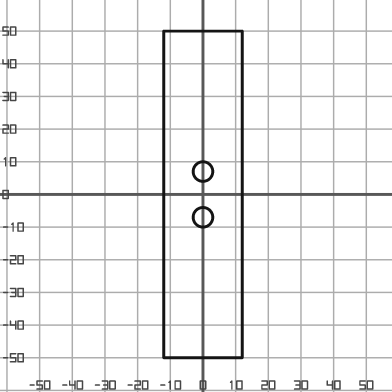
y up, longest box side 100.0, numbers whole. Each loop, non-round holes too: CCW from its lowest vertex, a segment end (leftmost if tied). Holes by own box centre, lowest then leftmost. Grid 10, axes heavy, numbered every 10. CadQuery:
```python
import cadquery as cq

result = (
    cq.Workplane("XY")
    .moveTo(-12.0, -50.0)
    .lineTo(12.0, -50.0)
    .lineTo(12.0, 50.0)
    .lineTo(-12.0, 50.0)
    .close()
    .moveTo(0.0, -7.0)
    .circle(3.0)
    .moveTo(0.0, 7.0)
    .circle(3.0)
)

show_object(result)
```